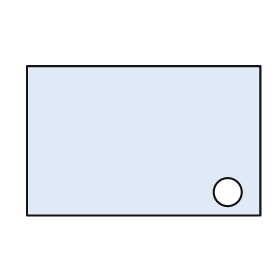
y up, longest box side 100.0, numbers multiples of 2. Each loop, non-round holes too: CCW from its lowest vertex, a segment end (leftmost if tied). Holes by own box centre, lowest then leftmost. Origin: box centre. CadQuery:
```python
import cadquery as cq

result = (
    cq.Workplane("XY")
    .moveTo(-50.0, -32.0)
    .lineTo(50.0, -32.0)
    .lineTo(50.0, 32.0)
    .lineTo(-50.0, 32.0)
    .close()
    .moveTo(36.0, -22.0)
    .circle(6.0)
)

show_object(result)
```